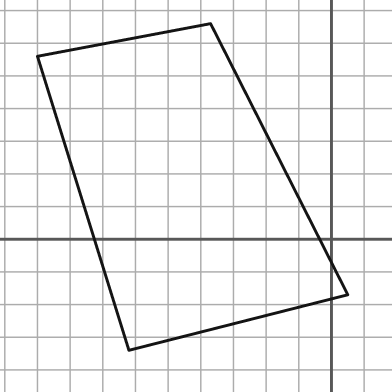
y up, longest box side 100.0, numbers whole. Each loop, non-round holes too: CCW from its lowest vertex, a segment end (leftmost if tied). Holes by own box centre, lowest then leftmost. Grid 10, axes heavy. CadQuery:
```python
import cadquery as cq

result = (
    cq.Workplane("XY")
    .moveTo(-62.0, -34.0)
    .lineTo(5.0, -17.0)
    .lineTo(-37.0, 66.0)
    .lineTo(-90.0, 56.0)
    .close()
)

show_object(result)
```